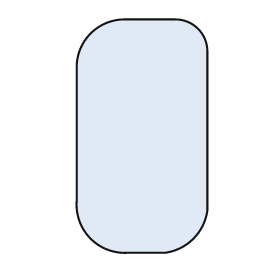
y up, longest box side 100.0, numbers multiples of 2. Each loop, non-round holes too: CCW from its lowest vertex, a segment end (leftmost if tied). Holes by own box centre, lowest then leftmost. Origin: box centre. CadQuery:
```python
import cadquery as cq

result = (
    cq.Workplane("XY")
    .moveTo(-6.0, -50.0)
    .lineTo(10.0, -50.0)
    .threePointArc((22.0, -44.0), (28.0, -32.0))
    .lineTo(28.0, 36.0)
    .threePointArc((24.0, 46.0), (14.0, 50.0))
    .lineTo(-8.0, 50.0)
    .threePointArc((-22.0, 44.0), (-28.0, 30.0))
    .lineTo(-28.0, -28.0)
    .threePointArc((-22.0, -44.0), (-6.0, -50.0))
    .close()
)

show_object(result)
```